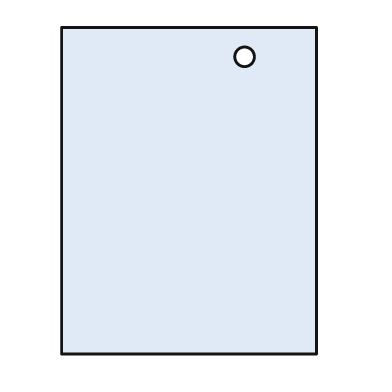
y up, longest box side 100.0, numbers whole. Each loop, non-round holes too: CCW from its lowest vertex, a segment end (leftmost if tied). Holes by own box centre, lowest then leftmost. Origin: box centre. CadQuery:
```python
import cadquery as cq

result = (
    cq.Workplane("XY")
    .moveTo(-39.0, -50.0)
    .lineTo(39.0, -50.0)
    .lineTo(39.0, 50.0)
    .lineTo(-39.0, 50.0)
    .close()
    .moveTo(17.0, 41.0)
    .circle(3.0)
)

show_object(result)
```